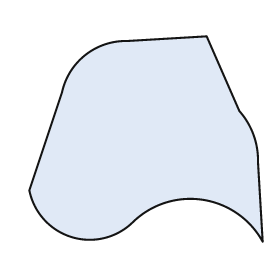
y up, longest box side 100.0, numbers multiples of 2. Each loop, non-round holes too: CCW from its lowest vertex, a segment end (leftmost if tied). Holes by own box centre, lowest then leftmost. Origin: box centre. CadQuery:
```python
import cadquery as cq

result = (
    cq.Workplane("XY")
    .moveTo(50.0, -44.0)
    .lineTo(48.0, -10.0)
    .threePointArc((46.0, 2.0), (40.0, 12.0))
    .lineTo(26.0, 44.0)
    .lineTo(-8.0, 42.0)
    .threePointArc((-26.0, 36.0), (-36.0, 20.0))
    .lineTo(-50.0, -22.0)
    .threePointArc((-32.0, -42.0), (-6.0, -36.0))
    .threePointArc((24.0, -26.0), (50.0, -44.0))
    .close()
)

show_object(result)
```